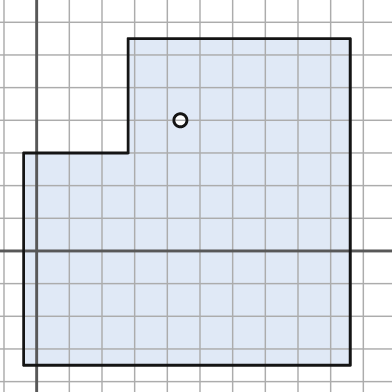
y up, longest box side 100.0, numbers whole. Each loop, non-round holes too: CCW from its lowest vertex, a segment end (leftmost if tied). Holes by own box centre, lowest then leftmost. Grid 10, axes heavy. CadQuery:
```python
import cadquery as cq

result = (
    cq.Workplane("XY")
    .moveTo(-4.0, -35.0)
    .lineTo(96.0, -35.0)
    .lineTo(96.0, 65.0)
    .lineTo(28.0, 65.0)
    .lineTo(28.0, 30.0)
    .lineTo(-4.0, 30.0)
    .close()
    .moveTo(44.0, 40.0)
    .circle(2.0)
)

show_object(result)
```